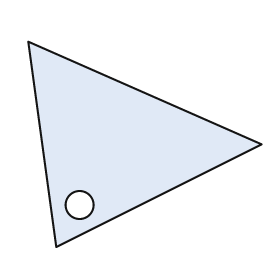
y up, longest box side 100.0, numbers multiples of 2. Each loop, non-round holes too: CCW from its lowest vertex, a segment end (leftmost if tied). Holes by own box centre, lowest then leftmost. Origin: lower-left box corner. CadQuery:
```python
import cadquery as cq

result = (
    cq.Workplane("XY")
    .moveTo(12.0, 0.0)
    .lineTo(100.0, 44.0)
    .lineTo(0.0, 88.0)
    .close()
    .moveTo(22.0, 18.0)
    .circle(6.0)
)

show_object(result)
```